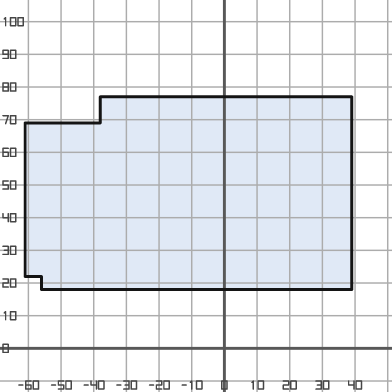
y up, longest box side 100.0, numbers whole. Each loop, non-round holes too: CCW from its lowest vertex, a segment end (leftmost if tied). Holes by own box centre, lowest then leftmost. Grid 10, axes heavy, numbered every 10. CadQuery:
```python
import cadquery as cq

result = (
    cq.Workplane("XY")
    .moveTo(-56.0, 18.0)
    .lineTo(39.0, 18.0)
    .lineTo(39.0, 77.0)
    .lineTo(-38.0, 77.0)
    .lineTo(-38.0, 69.0)
    .lineTo(-61.0, 69.0)
    .lineTo(-61.0, 22.0)
    .lineTo(-56.0, 22.0)
    .close()
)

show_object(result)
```